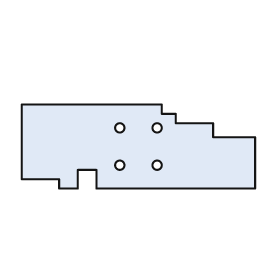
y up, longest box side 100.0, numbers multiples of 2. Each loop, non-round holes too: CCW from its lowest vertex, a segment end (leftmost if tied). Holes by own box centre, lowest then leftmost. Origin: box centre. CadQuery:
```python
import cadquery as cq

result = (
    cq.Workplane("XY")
    .moveTo(-34.0, -18.0)
    .lineTo(-26.0, -18.0)
    .lineTo(-26.0, -10.0)
    .lineTo(-18.0, -10.0)
    .lineTo(-18.0, -18.0)
    .lineTo(50.0, -18.0)
    .lineTo(50.0, 4.0)
    .lineTo(32.0, 4.0)
    .lineTo(32.0, 10.0)
    .lineTo(16.0, 10.0)
    .lineTo(16.0, 14.0)
    .lineTo(10.0, 14.0)
    .lineTo(10.0, 18.0)
    .lineTo(-50.0, 18.0)
    .lineTo(-50.0, -14.0)
    .lineTo(-34.0, -14.0)
    .close()
    .moveTo(-8.0, -8.0)
    .circle(2.0)
    .moveTo(8.0, -8.0)
    .circle(2.0)
    .moveTo(-8.0, 8.0)
    .circle(2.0)
    .moveTo(8.0, 8.0)
    .circle(2.0)
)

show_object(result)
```